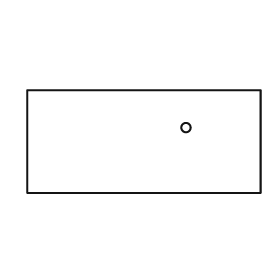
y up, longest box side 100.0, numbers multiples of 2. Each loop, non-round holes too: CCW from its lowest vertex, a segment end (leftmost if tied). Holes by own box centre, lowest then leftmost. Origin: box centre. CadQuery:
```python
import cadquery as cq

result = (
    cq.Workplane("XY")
    .moveTo(-50.0, -22.0)
    .lineTo(50.0, -22.0)
    .lineTo(50.0, 22.0)
    .lineTo(-50.0, 22.0)
    .close()
    .moveTo(18.0, 6.0)
    .circle(2.0)
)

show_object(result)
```